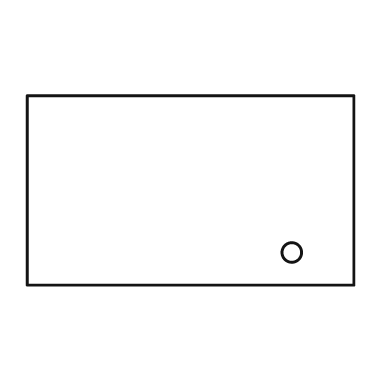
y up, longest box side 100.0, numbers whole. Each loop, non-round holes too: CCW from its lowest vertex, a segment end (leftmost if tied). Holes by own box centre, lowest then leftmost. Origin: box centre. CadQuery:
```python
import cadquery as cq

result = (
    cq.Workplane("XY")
    .moveTo(-50.0, -29.0)
    .lineTo(50.0, -29.0)
    .lineTo(50.0, 29.0)
    .lineTo(-50.0, 29.0)
    .close()
    .moveTo(31.0, -19.0)
    .circle(3.0)
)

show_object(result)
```